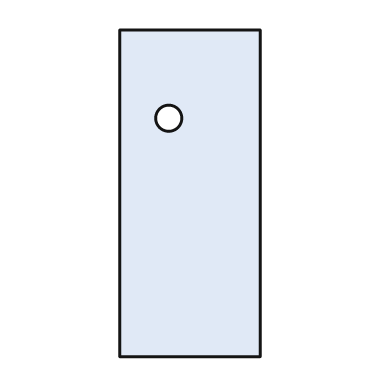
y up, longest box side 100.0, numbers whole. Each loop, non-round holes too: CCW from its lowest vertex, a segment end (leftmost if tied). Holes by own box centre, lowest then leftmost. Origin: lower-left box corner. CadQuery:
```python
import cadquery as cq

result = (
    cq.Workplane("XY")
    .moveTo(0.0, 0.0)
    .lineTo(43.0, 0.0)
    .lineTo(43.0, 100.0)
    .lineTo(0.0, 100.0)
    .close()
    .moveTo(15.0, 73.0)
    .circle(4.0)
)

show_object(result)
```